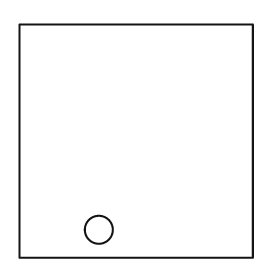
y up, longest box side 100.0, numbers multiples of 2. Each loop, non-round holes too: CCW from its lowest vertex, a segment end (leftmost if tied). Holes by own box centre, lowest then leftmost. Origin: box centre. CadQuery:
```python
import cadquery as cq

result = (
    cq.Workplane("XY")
    .moveTo(-50.0, -50.0)
    .lineTo(50.0, -50.0)
    .lineTo(50.0, 50.0)
    .lineTo(-50.0, 50.0)
    .close()
    .moveTo(-16.0, -38.0)
    .circle(6.0)
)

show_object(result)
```